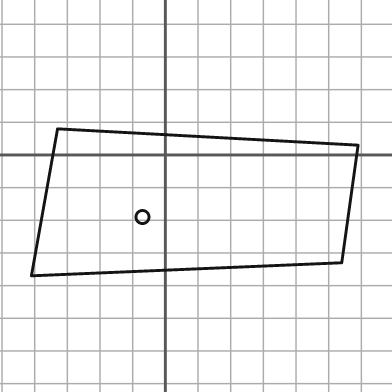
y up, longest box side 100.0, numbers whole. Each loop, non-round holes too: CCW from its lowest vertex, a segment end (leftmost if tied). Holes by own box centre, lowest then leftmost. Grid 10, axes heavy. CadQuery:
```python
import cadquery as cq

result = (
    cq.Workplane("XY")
    .moveTo(-41.0, -37.0)
    .lineTo(54.0, -33.0)
    .lineTo(59.0, 3.0)
    .lineTo(-33.0, 8.0)
    .close()
    .moveTo(-7.0, -19.0)
    .circle(2.0)
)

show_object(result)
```